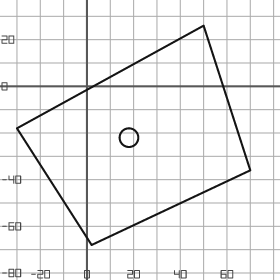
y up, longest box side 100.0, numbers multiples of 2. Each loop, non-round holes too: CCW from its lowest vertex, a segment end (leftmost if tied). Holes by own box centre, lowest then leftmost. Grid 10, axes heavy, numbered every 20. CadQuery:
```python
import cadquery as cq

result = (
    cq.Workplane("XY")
    .moveTo(2.0, -68.0)
    .lineTo(70.0, -36.0)
    .lineTo(50.0, 26.0)
    .lineTo(-30.0, -18.0)
    .close()
    .moveTo(18.0, -22.0)
    .circle(4.0)
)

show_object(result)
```